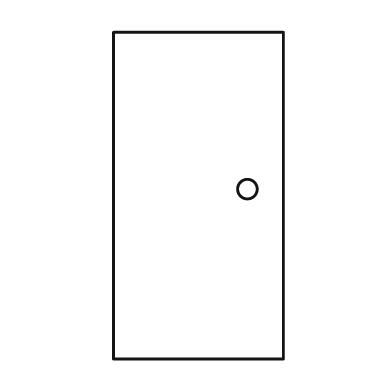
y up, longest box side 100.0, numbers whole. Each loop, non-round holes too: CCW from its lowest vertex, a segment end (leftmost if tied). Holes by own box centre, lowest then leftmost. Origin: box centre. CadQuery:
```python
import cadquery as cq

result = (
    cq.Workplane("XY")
    .moveTo(-26.0, -50.0)
    .lineTo(26.0, -50.0)
    .lineTo(26.0, 50.0)
    .lineTo(-26.0, 50.0)
    .close()
    .moveTo(15.0, 2.0)
    .circle(3.0)
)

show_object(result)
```